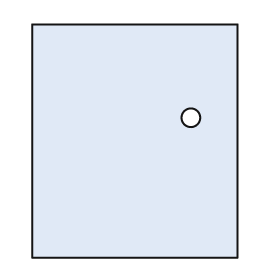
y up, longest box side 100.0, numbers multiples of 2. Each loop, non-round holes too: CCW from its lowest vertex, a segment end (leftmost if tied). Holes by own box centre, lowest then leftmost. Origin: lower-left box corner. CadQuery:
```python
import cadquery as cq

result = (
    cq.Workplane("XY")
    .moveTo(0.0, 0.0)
    .lineTo(88.0, 0.0)
    .lineTo(88.0, 100.0)
    .lineTo(0.0, 100.0)
    .close()
    .moveTo(68.0, 60.0)
    .circle(4.0)
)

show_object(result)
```